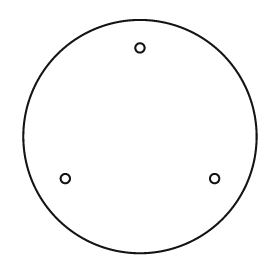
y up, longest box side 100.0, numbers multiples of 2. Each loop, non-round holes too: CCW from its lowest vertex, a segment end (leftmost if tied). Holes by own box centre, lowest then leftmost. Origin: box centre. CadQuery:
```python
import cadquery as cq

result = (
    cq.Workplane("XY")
    .moveTo(0.0, 0.0)
    .circle(50.0)
    .moveTo(-32.0, -18.0)
    .circle(2.0)
    .moveTo(32.0, -18.0)
    .circle(2.0)
    .moveTo(0.0, 38.0)
    .circle(2.0)
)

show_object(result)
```